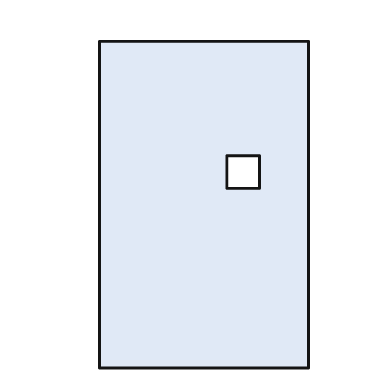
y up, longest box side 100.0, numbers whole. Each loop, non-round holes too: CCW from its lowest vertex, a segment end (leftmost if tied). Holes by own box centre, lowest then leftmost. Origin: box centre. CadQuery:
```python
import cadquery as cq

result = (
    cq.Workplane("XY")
    .moveTo(-32.0, -50.0)
    .lineTo(32.0, -50.0)
    .lineTo(32.0, 50.0)
    .lineTo(-32.0, 50.0)
    .close()
    .moveTo(7.0, 5.0)
    .lineTo(17.0, 5.0)
    .lineTo(17.0, 15.0)
    .lineTo(7.0, 15.0)
    .close()
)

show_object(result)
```